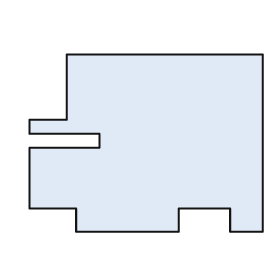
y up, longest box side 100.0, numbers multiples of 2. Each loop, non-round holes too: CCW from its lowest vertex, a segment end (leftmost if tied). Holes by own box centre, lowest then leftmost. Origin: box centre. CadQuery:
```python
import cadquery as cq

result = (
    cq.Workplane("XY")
    .moveTo(-30.0, -38.0)
    .lineTo(14.0, -38.0)
    .lineTo(14.0, -28.0)
    .lineTo(36.0, -28.0)
    .lineTo(36.0, -38.0)
    .lineTo(50.0, -38.0)
    .lineTo(50.0, 38.0)
    .lineTo(-34.0, 38.0)
    .lineTo(-34.0, 10.0)
    .lineTo(-50.0, 10.0)
    .lineTo(-50.0, 4.0)
    .lineTo(-20.0, 4.0)
    .lineTo(-20.0, -2.0)
    .lineTo(-50.0, -2.0)
    .lineTo(-50.0, -28.0)
    .lineTo(-30.0, -28.0)
    .close()
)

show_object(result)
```